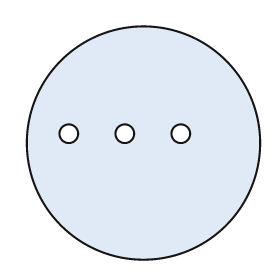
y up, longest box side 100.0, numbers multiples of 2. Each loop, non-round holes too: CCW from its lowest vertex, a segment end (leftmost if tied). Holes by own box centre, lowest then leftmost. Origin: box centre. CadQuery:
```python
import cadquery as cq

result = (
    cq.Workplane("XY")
    .moveTo(0.0, 0.0)
    .circle(50.0)
    .moveTo(-32.0, 4.0)
    .circle(4.0)
    .moveTo(-8.0, 4.0)
    .circle(4.0)
    .moveTo(16.0, 4.0)
    .circle(4.0)
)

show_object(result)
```